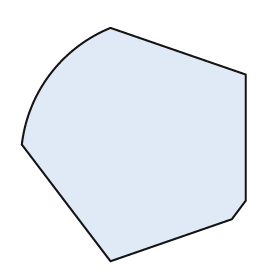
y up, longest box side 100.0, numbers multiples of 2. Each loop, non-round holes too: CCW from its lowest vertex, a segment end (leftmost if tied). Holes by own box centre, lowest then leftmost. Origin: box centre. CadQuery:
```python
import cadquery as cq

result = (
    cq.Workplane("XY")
    .moveTo(-10.0, -50.0)
    .lineTo(42.0, -32.0)
    .lineTo(48.0, -24.0)
    .lineTo(48.0, 30.0)
    .lineTo(-10.0, 50.0)
    .threePointArc((-36.0, 30.0), (-48.0, 0.0))
    .close()
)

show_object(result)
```